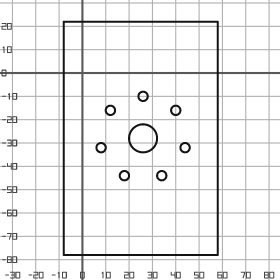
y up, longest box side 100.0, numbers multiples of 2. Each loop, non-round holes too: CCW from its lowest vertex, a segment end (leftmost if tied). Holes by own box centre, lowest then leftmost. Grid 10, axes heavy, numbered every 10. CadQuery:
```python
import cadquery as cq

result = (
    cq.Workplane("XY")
    .moveTo(-8.0, -78.0)
    .lineTo(58.0, -78.0)
    .lineTo(58.0, 22.0)
    .lineTo(-8.0, 22.0)
    .close()
    .moveTo(18.0, -44.0)
    .circle(2.0)
    .moveTo(34.0, -44.0)
    .circle(2.0)
    .moveTo(8.0, -32.0)
    .circle(2.0)
    .moveTo(44.0, -32.0)
    .circle(2.0)
    .moveTo(26.0, -28.0)
    .circle(6.0)
    .moveTo(12.0, -16.0)
    .circle(2.0)
    .moveTo(40.0, -16.0)
    .circle(2.0)
    .moveTo(26.0, -10.0)
    .circle(2.0)
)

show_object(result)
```